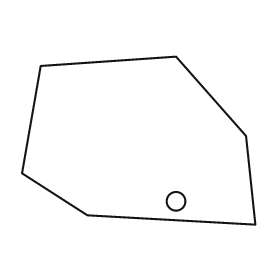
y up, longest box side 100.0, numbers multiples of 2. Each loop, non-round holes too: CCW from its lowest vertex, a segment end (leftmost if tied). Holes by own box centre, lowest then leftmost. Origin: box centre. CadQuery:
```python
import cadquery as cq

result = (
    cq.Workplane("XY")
    .moveTo(50.0, -36.0)
    .lineTo(46.0, 2.0)
    .lineTo(16.0, 36.0)
    .lineTo(-42.0, 32.0)
    .lineTo(-50.0, -14.0)
    .lineTo(-22.0, -32.0)
    .close()
    .moveTo(16.0, -26.0)
    .circle(4.0)
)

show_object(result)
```